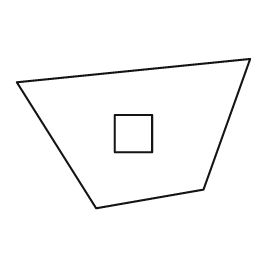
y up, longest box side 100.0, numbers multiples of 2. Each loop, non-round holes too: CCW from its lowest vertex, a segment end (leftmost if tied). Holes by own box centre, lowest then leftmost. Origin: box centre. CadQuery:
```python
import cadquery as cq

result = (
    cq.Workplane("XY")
    .moveTo(-16.0, -32.0)
    .lineTo(30.0, -24.0)
    .lineTo(50.0, 32.0)
    .lineTo(-50.0, 22.0)
    .close()
    .moveTo(-8.0, -8.0)
    .lineTo(8.0, -8.0)
    .lineTo(8.0, 8.0)
    .lineTo(-8.0, 8.0)
    .close()
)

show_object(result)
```